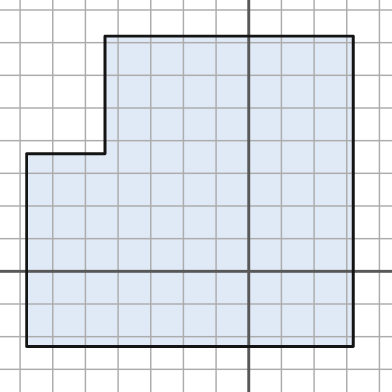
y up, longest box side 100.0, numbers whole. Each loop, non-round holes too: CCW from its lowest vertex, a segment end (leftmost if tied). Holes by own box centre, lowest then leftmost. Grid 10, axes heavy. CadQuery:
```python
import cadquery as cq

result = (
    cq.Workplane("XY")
    .moveTo(-68.0, -23.0)
    .lineTo(32.0, -23.0)
    .lineTo(32.0, 72.0)
    .lineTo(-44.0, 72.0)
    .lineTo(-44.0, 36.0)
    .lineTo(-68.0, 36.0)
    .close()
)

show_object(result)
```